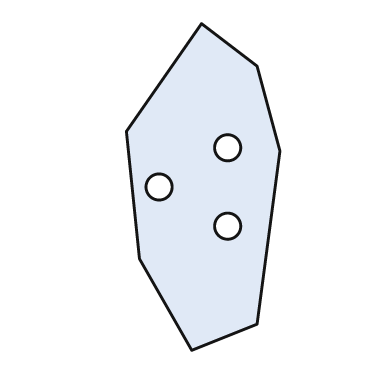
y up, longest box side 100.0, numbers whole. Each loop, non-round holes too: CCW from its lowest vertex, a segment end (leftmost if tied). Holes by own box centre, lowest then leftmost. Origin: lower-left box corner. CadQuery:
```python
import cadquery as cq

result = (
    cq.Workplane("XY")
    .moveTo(20.0, 0.0)
    .lineTo(40.0, 8.0)
    .lineTo(47.0, 61.0)
    .lineTo(40.0, 87.0)
    .lineTo(23.0, 100.0)
    .lineTo(0.0, 67.0)
    .lineTo(4.0, 28.0)
    .close()
    .moveTo(31.0, 38.0)
    .circle(4.0)
    .moveTo(10.0, 50.0)
    .circle(4.0)
    .moveTo(31.0, 62.0)
    .circle(4.0)
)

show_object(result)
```